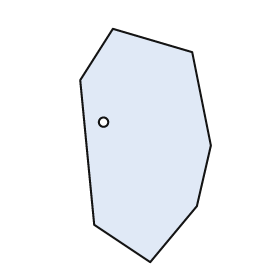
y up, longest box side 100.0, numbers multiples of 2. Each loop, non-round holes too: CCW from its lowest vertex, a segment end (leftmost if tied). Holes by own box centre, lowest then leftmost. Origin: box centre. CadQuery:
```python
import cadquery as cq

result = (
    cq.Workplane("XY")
    .moveTo(2.0, -50.0)
    .lineTo(22.0, -26.0)
    .lineTo(28.0, 0.0)
    .lineTo(20.0, 40.0)
    .lineTo(-14.0, 50.0)
    .lineTo(-28.0, 28.0)
    .lineTo(-22.0, -34.0)
    .close()
    .moveTo(-18.0, 10.0)
    .circle(2.0)
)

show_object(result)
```